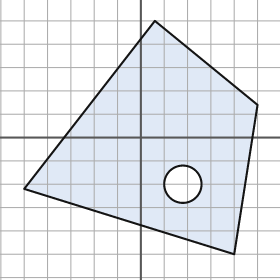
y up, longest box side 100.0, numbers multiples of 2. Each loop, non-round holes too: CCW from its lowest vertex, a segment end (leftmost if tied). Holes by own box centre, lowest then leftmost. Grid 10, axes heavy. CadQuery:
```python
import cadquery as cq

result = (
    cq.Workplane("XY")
    .moveTo(40.0, -50.0)
    .lineTo(50.0, 14.0)
    .lineTo(6.0, 50.0)
    .lineTo(-50.0, -22.0)
    .close()
    .moveTo(18.0, -20.0)
    .circle(8.0)
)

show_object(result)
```